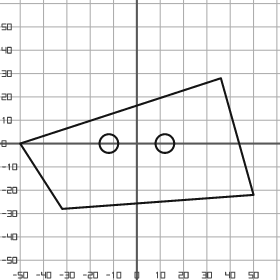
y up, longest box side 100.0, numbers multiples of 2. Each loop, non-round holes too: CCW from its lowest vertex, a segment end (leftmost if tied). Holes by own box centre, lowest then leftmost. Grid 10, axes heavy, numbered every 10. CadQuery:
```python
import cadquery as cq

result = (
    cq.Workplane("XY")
    .moveTo(-32.0, -28.0)
    .lineTo(50.0, -22.0)
    .lineTo(36.0, 28.0)
    .lineTo(-50.0, 0.0)
    .close()
    .moveTo(-12.0, 0.0)
    .circle(4.0)
    .moveTo(12.0, 0.0)
    .circle(4.0)
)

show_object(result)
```